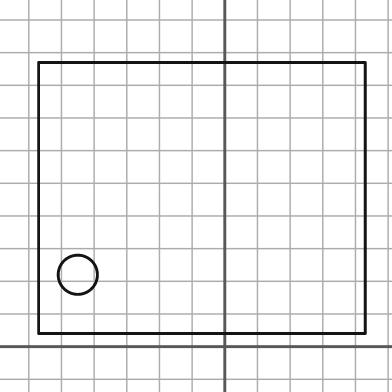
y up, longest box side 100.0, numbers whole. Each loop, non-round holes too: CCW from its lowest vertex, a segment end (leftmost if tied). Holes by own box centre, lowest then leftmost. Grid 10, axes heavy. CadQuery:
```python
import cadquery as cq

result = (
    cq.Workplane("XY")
    .moveTo(-57.0, 4.0)
    .lineTo(43.0, 4.0)
    .lineTo(43.0, 87.0)
    .lineTo(-57.0, 87.0)
    .close()
    .moveTo(-45.0, 22.0)
    .circle(6.0)
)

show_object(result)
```